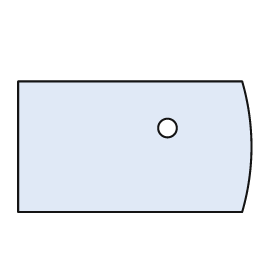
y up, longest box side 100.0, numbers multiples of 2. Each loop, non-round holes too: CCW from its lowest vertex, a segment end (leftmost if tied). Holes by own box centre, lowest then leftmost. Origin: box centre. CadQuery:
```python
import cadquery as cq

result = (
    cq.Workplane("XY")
    .moveTo(-50.0, -28.0)
    .lineTo(46.0, -28.0)
    .threePointArc((50.0, 0.0), (46.0, 28.0))
    .lineTo(-50.0, 28.0)
    .close()
    .moveTo(14.0, 8.0)
    .circle(4.0)
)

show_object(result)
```